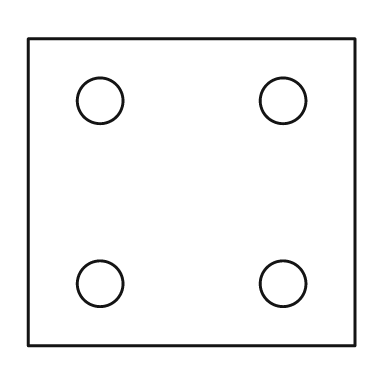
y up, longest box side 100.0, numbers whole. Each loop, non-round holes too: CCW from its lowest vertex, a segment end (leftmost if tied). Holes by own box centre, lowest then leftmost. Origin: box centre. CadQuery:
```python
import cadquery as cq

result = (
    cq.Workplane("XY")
    .moveTo(-50.0, -47.0)
    .lineTo(50.0, -47.0)
    .lineTo(50.0, 47.0)
    .lineTo(-50.0, 47.0)
    .close()
    .moveTo(-28.0, -28.0)
    .circle(7.0)
    .moveTo(28.0, -28.0)
    .circle(7.0)
    .moveTo(-28.0, 28.0)
    .circle(7.0)
    .moveTo(28.0, 28.0)
    .circle(7.0)
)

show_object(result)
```